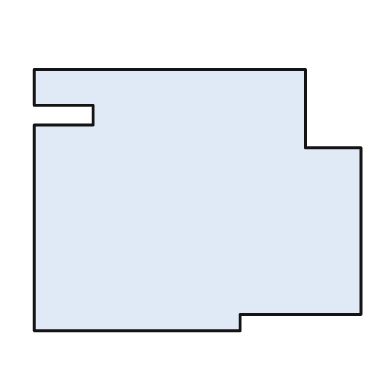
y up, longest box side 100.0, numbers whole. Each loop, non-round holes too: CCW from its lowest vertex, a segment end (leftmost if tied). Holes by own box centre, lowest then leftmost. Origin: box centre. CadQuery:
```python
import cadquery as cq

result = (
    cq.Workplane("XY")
    .moveTo(-50.0, -40.0)
    .lineTo(13.0, -40.0)
    .lineTo(13.0, -35.0)
    .lineTo(50.0, -35.0)
    .lineTo(50.0, 16.0)
    .lineTo(33.0, 16.0)
    .lineTo(33.0, 40.0)
    .lineTo(-50.0, 40.0)
    .lineTo(-50.0, 29.0)
    .lineTo(-32.0, 29.0)
    .lineTo(-32.0, 23.0)
    .lineTo(-50.0, 23.0)
    .close()
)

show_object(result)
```